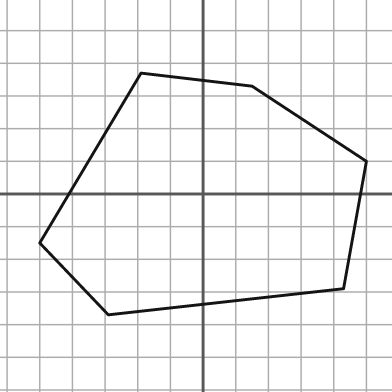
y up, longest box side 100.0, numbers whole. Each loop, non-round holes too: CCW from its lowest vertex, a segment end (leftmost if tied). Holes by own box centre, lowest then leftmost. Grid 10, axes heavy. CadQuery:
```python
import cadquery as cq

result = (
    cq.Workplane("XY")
    .moveTo(-29.0, -37.0)
    .lineTo(43.0, -29.0)
    .lineTo(50.0, 10.0)
    .lineTo(15.0, 33.0)
    .lineTo(-19.0, 37.0)
    .lineTo(-50.0, -15.0)
    .close()
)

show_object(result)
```